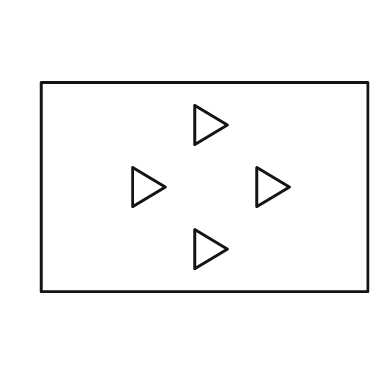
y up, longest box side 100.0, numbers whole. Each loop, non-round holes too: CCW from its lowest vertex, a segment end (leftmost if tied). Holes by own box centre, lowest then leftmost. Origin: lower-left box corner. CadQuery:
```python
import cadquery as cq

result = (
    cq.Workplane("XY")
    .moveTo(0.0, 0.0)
    .lineTo(100.0, 0.0)
    .lineTo(100.0, 64.0)
    .lineTo(0.0, 64.0)
    .close()
    .moveTo(47.0, 7.0)
    .lineTo(57.0, 13.0)
    .lineTo(47.0, 19.0)
    .close()
    .moveTo(28.0, 26.0)
    .lineTo(38.0, 32.0)
    .lineTo(28.0, 38.0)
    .close()
    .moveTo(66.0, 26.0)
    .lineTo(76.0, 32.0)
    .lineTo(66.0, 38.0)
    .close()
    .moveTo(47.0, 45.0)
    .lineTo(57.0, 51.0)
    .lineTo(47.0, 57.0)
    .close()
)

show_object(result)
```